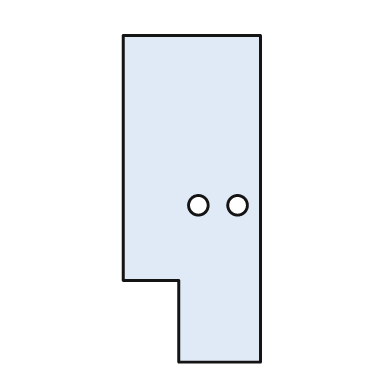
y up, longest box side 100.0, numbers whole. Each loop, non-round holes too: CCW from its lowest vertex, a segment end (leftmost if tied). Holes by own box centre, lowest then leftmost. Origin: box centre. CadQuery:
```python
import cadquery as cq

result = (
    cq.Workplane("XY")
    .moveTo(-4.0, -50.0)
    .lineTo(21.0, -50.0)
    .lineTo(21.0, 50.0)
    .lineTo(-21.0, 50.0)
    .lineTo(-21.0, -25.0)
    .lineTo(-4.0, -25.0)
    .close()
    .moveTo(2.0, -2.0)
    .circle(3.0)
    .moveTo(14.0, -2.0)
    .circle(3.0)
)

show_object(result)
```